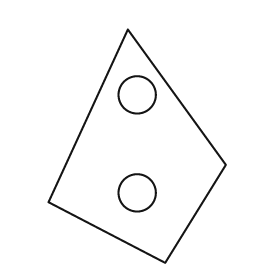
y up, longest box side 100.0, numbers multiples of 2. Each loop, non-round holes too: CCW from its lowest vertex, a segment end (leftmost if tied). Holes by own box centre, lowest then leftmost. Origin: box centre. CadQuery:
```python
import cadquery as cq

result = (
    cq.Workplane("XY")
    .moveTo(12.0, -50.0)
    .lineTo(38.0, -8.0)
    .lineTo(-4.0, 50.0)
    .lineTo(-38.0, -24.0)
    .close()
    .moveTo(0.0, -20.0)
    .circle(8.0)
    .moveTo(0.0, 22.0)
    .circle(8.0)
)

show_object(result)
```